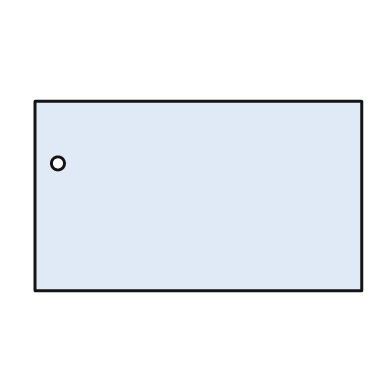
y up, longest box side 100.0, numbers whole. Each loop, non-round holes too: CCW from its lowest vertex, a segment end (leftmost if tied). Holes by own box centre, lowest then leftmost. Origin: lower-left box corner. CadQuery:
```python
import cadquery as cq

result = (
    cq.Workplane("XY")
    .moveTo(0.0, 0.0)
    .lineTo(100.0, 0.0)
    .lineTo(100.0, 58.0)
    .lineTo(0.0, 58.0)
    .close()
    .moveTo(7.0, 39.0)
    .circle(2.0)
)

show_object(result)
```